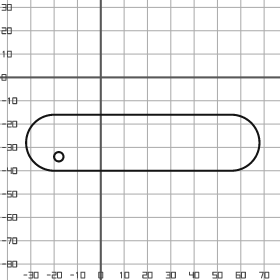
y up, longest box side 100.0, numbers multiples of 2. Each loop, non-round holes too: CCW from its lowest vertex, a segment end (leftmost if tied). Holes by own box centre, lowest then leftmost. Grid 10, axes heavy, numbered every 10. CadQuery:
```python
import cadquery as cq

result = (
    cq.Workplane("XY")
    .moveTo(-20.0, -40.0)
    .lineTo(56.0, -40.0)
    .threePointArc((68.0, -28.0), (56.0, -16.0))
    .lineTo(-20.0, -16.0)
    .threePointArc((-32.0, -28.0), (-20.0, -40.0))
    .close()
    .moveTo(-18.0, -34.0)
    .circle(2.0)
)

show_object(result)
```